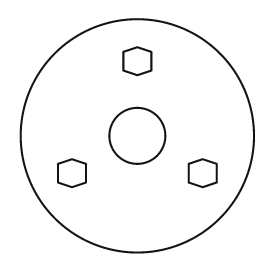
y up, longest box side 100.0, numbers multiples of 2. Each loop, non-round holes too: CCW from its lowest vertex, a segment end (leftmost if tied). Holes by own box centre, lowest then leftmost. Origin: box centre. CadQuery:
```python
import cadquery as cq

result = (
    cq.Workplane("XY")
    .moveTo(0.0, 0.0)
    .circle(50.0)
    .moveTo(-28.0, -22.0)
    .lineTo(-22.0, -20.0)
    .lineTo(-22.0, -12.0)
    .lineTo(-28.0, -10.0)
    .lineTo(-34.0, -12.0)
    .lineTo(-34.0, -20.0)
    .close()
    .moveTo(28.0, -22.0)
    .lineTo(34.0, -20.0)
    .lineTo(34.0, -12.0)
    .lineTo(28.0, -10.0)
    .lineTo(22.0, -12.0)
    .lineTo(22.0, -20.0)
    .close()
    .moveTo(0.0, 0.0)
    .circle(12.0)
    .moveTo(0.0, 26.0)
    .lineTo(6.0, 28.0)
    .lineTo(6.0, 36.0)
    .lineTo(0.0, 38.0)
    .lineTo(-6.0, 36.0)
    .lineTo(-6.0, 28.0)
    .close()
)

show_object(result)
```